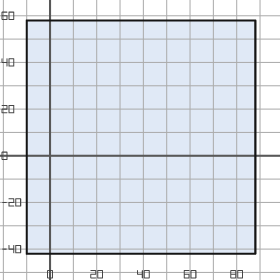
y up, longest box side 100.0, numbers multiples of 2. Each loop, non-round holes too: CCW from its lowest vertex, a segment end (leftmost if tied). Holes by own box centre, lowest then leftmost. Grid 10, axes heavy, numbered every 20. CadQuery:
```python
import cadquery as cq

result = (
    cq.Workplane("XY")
    .moveTo(-10.0, -42.0)
    .lineTo(88.0, -42.0)
    .lineTo(88.0, 58.0)
    .lineTo(-10.0, 58.0)
    .close()
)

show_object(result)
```